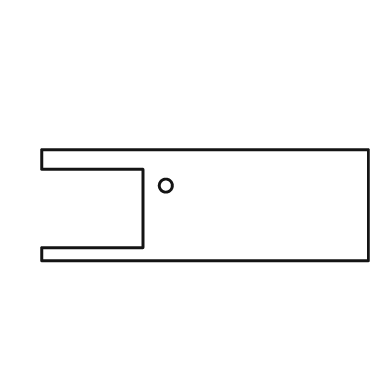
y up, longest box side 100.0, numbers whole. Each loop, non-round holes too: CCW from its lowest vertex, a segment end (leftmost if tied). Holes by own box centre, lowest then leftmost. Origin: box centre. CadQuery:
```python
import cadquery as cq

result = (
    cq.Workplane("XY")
    .moveTo(-50.0, -17.0)
    .lineTo(50.0, -17.0)
    .lineTo(50.0, 17.0)
    .lineTo(-50.0, 17.0)
    .lineTo(-50.0, 11.0)
    .lineTo(-19.0, 11.0)
    .lineTo(-19.0, -13.0)
    .lineTo(-50.0, -13.0)
    .close()
    .moveTo(-12.0, 6.0)
    .circle(2.0)
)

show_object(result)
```